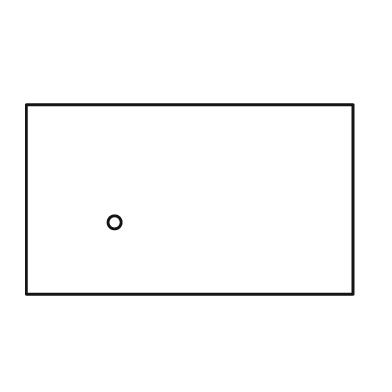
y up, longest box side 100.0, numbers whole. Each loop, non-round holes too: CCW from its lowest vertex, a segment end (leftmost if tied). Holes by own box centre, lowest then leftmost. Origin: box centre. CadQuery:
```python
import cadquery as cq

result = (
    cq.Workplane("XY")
    .moveTo(-50.0, -29.0)
    .lineTo(50.0, -29.0)
    .lineTo(50.0, 29.0)
    .lineTo(-50.0, 29.0)
    .close()
    .moveTo(-23.0, -7.0)
    .circle(2.0)
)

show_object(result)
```